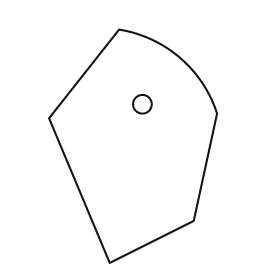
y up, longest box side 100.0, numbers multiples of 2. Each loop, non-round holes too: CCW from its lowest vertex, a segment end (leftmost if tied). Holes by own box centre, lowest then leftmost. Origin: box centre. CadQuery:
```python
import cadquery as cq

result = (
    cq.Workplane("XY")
    .moveTo(-10.0, -50.0)
    .lineTo(26.0, -32.0)
    .lineTo(36.0, 14.0)
    .threePointArc((20.0, 38.0), (-6.0, 50.0))
    .lineTo(-36.0, 12.0)
    .close()
    .moveTo(4.0, 18.0)
    .circle(4.0)
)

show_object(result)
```